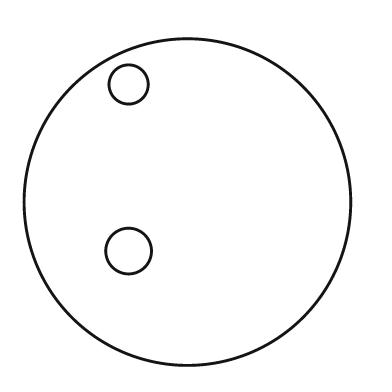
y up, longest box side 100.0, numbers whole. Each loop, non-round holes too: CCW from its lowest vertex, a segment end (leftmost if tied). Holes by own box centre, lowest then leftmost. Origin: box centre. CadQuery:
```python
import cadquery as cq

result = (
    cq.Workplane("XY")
    .moveTo(0.0, 0.0)
    .circle(50.0)
    .moveTo(-18.0, -15.0)
    .circle(7.0)
    .moveTo(-18.0, 36.0)
    .circle(6.0)
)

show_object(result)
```